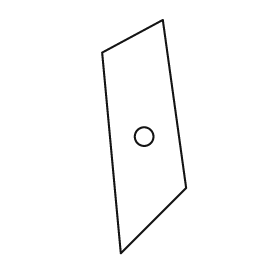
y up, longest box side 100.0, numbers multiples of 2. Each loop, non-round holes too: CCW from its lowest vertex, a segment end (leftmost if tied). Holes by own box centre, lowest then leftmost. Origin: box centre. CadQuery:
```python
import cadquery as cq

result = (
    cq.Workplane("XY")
    .moveTo(-10.0, -50.0)
    .lineTo(18.0, -22.0)
    .lineTo(8.0, 50.0)
    .lineTo(-18.0, 36.0)
    .close()
    .moveTo(0.0, 0.0)
    .circle(4.0)
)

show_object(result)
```